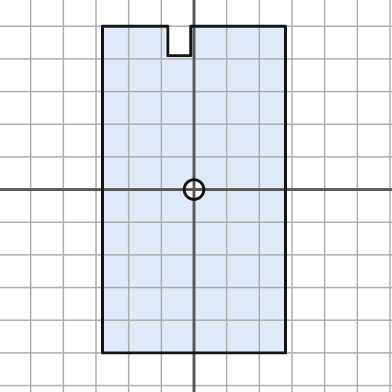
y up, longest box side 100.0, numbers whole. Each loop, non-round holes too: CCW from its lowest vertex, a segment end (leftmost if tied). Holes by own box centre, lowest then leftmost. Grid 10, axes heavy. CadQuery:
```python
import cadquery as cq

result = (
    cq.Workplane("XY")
    .moveTo(-28.0, -50.0)
    .lineTo(28.0, -50.0)
    .lineTo(28.0, 50.0)
    .lineTo(-1.0, 50.0)
    .lineTo(-1.0, 41.0)
    .lineTo(-8.0, 41.0)
    .lineTo(-8.0, 50.0)
    .lineTo(-28.0, 50.0)
    .close()
    .moveTo(0.0, 0.0)
    .circle(3.0)
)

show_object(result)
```